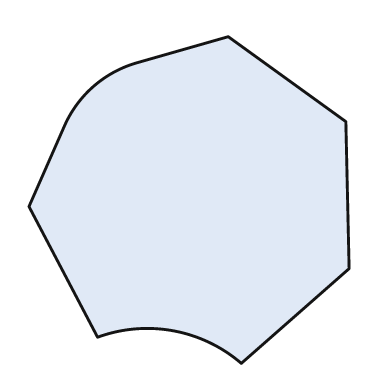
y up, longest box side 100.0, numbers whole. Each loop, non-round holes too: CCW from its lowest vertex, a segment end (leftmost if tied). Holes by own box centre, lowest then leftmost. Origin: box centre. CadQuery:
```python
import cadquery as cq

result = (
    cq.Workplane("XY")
    .moveTo(16.0, -50.0)
    .lineTo(49.0, -21.0)
    .lineTo(48.0, 24.0)
    .lineTo(12.0, 50.0)
    .lineTo(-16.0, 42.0)
    .threePointArc((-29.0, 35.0), (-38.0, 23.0))
    .lineTo(-49.0, -2.0)
    .lineTo(-28.0, -42.0)
    .threePointArc((-5.0, -40.0), (16.0, -50.0))
    .close()
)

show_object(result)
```